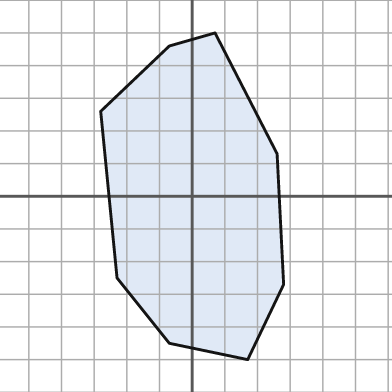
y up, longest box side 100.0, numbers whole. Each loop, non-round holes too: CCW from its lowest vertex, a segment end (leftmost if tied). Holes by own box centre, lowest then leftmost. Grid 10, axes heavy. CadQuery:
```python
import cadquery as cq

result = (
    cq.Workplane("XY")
    .moveTo(17.0, -50.0)
    .lineTo(28.0, -27.0)
    .lineTo(26.0, 13.0)
    .lineTo(7.0, 50.0)
    .lineTo(-7.0, 46.0)
    .lineTo(-28.0, 26.0)
    .lineTo(-23.0, -25.0)
    .lineTo(-7.0, -45.0)
    .close()
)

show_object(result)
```